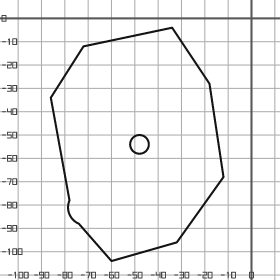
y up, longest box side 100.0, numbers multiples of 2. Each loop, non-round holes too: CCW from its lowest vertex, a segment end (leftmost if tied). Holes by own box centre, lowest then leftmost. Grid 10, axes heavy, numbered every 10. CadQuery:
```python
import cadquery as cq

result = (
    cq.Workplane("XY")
    .moveTo(-60.0, -104.0)
    .lineTo(-32.0, -96.0)
    .lineTo(-12.0, -68.0)
    .lineTo(-18.0, -28.0)
    .lineTo(-34.0, -4.0)
    .lineTo(-72.0, -12.0)
    .lineTo(-86.0, -34.0)
    .lineTo(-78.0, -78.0)
    .threePointArc((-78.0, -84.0), (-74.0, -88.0))
    .close()
    .moveTo(-48.0, -54.0)
    .circle(4.0)
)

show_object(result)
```